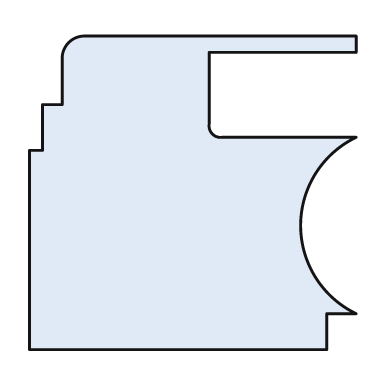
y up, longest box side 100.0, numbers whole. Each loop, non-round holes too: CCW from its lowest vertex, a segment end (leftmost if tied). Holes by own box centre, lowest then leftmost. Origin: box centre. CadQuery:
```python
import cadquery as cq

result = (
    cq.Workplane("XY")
    .moveTo(-50.0, -48.0)
    .lineTo(41.0, -48.0)
    .lineTo(41.0, -37.0)
    .lineTo(50.0, -37.0)
    .threePointArc((33.0, -10.0), (50.0, 17.0))
    .lineTo(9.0, 17.0)
    .threePointArc((6.0, 18.0), (5.0, 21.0))
    .lineTo(5.0, 43.0)
    .lineTo(50.0, 43.0)
    .lineTo(50.0, 48.0)
    .lineTo(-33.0, 48.0)
    .threePointArc((-38.0, 46.0), (-40.0, 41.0))
    .lineTo(-40.0, 27.0)
    .lineTo(-46.0, 27.0)
    .lineTo(-46.0, 13.0)
    .lineTo(-50.0, 13.0)
    .close()
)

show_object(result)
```